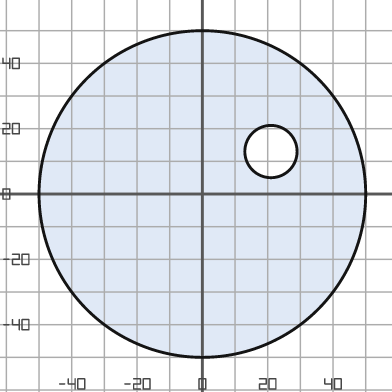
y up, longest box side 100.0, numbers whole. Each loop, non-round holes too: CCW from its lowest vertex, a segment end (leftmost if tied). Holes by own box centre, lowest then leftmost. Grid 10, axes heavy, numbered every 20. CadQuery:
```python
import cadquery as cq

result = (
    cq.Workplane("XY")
    .moveTo(0.0, 0.0)
    .circle(50.0)
    .moveTo(21.0, 13.0)
    .circle(8.0)
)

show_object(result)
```